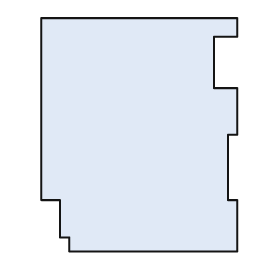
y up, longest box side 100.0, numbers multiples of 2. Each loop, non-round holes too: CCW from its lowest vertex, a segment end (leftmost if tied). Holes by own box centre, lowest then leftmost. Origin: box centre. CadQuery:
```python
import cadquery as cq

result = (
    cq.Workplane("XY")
    .moveTo(-30.0, -50.0)
    .lineTo(42.0, -50.0)
    .lineTo(42.0, -28.0)
    .lineTo(38.0, -28.0)
    .lineTo(38.0, 0.0)
    .lineTo(42.0, 0.0)
    .lineTo(42.0, 20.0)
    .lineTo(32.0, 20.0)
    .lineTo(32.0, 42.0)
    .lineTo(42.0, 42.0)
    .lineTo(42.0, 50.0)
    .lineTo(-42.0, 50.0)
    .lineTo(-42.0, -28.0)
    .lineTo(-34.0, -28.0)
    .lineTo(-34.0, -44.0)
    .lineTo(-30.0, -44.0)
    .close()
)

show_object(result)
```